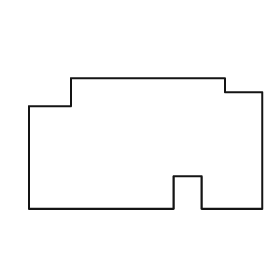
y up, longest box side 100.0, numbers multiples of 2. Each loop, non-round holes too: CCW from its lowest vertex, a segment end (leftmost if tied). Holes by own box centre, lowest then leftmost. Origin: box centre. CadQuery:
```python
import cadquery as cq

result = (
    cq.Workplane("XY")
    .moveTo(-50.0, -28.0)
    .lineTo(12.0, -28.0)
    .lineTo(12.0, -14.0)
    .lineTo(24.0, -14.0)
    .lineTo(24.0, -28.0)
    .lineTo(50.0, -28.0)
    .lineTo(50.0, 22.0)
    .lineTo(34.0, 22.0)
    .lineTo(34.0, 28.0)
    .lineTo(-32.0, 28.0)
    .lineTo(-32.0, 16.0)
    .lineTo(-50.0, 16.0)
    .close()
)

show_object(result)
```